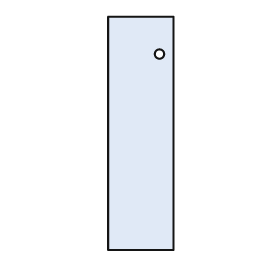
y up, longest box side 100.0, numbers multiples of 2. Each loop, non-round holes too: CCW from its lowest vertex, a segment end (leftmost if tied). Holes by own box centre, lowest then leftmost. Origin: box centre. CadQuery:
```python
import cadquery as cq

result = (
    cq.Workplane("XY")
    .moveTo(-14.0, -50.0)
    .lineTo(14.0, -50.0)
    .lineTo(14.0, 50.0)
    .lineTo(-14.0, 50.0)
    .close()
    .moveTo(8.0, 34.0)
    .circle(2.0)
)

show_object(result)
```